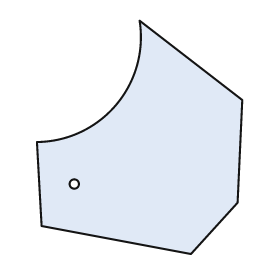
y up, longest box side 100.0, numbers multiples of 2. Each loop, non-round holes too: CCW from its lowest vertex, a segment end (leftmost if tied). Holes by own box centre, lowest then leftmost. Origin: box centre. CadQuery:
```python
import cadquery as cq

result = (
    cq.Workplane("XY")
    .moveTo(22.0, -50.0)
    .lineTo(42.0, -28.0)
    .lineTo(44.0, 16.0)
    .lineTo(0.0, 50.0)
    .threePointArc((-10.0, 14.0), (-44.0, -2.0))
    .lineTo(-42.0, -38.0)
    .close()
    .moveTo(-28.0, -20.0)
    .circle(2.0)
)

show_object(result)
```